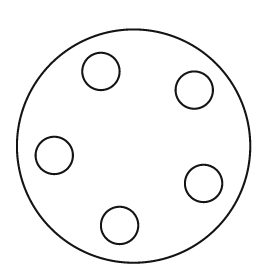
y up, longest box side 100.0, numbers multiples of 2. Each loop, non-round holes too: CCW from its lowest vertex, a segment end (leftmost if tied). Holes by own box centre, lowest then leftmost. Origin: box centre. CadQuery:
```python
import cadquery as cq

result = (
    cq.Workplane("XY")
    .moveTo(0.0, 0.0)
    .circle(50.0)
    .moveTo(-6.0, -34.0)
    .circle(8.0)
    .moveTo(30.0, -16.0)
    .circle(8.0)
    .moveTo(-34.0, -4.0)
    .circle(8.0)
    .moveTo(26.0, 24.0)
    .circle(8.0)
    .moveTo(-14.0, 32.0)
    .circle(8.0)
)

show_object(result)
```